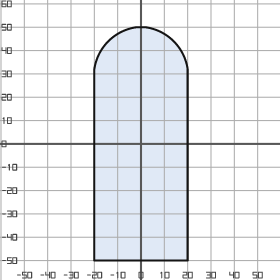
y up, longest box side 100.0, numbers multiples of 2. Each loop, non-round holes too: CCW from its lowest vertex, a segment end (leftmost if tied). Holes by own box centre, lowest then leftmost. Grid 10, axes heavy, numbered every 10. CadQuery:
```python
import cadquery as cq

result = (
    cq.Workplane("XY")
    .moveTo(-20.0, -50.0)
    .lineTo(20.0, -50.0)
    .lineTo(20.0, 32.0)
    .threePointArc((14.0, 44.0), (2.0, 50.0))
    .lineTo(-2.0, 50.0)
    .threePointArc((-14.0, 44.0), (-20.0, 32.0))
    .close()
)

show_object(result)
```